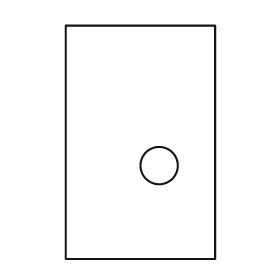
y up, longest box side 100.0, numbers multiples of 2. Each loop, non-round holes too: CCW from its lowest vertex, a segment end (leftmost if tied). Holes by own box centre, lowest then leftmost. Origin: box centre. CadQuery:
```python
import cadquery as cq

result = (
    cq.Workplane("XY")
    .moveTo(-32.0, -50.0)
    .lineTo(32.0, -50.0)
    .lineTo(32.0, 50.0)
    .lineTo(-32.0, 50.0)
    .close()
    .moveTo(8.0, -10.0)
    .circle(8.0)
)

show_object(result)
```